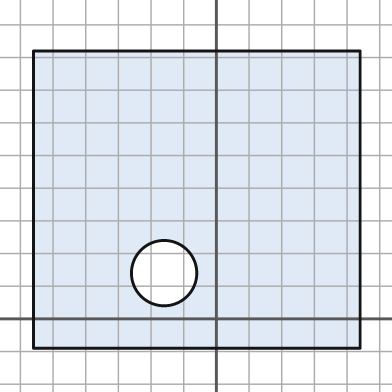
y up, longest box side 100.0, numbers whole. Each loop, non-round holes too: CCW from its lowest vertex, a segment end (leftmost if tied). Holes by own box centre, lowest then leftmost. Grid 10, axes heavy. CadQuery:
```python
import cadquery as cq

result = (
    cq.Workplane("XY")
    .moveTo(-56.0, -9.0)
    .lineTo(44.0, -9.0)
    .lineTo(44.0, 82.0)
    .lineTo(-56.0, 82.0)
    .close()
    .moveTo(-16.0, 14.0)
    .circle(10.0)
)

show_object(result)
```